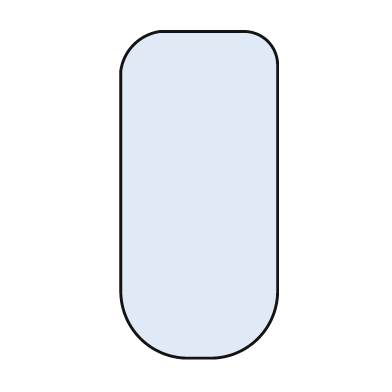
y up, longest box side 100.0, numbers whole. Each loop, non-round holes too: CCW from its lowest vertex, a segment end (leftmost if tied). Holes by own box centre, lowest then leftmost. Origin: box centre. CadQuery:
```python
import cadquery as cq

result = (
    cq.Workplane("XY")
    .moveTo(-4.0, -50.0)
    .lineTo(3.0, -50.0)
    .threePointArc((18.0, -44.0), (24.0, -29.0))
    .lineTo(24.0, 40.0)
    .threePointArc((21.0, 47.0), (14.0, 50.0))
    .lineTo(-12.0, 50.0)
    .threePointArc((-20.0, 46.0), (-24.0, 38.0))
    .lineTo(-24.0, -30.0)
    .threePointArc((-18.0, -44.0), (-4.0, -50.0))
    .close()
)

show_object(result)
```